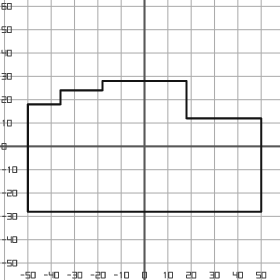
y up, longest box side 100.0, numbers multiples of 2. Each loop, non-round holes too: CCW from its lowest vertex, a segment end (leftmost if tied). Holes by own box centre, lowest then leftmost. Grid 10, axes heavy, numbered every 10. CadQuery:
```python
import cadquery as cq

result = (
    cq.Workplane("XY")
    .moveTo(-50.0, -28.0)
    .lineTo(50.0, -28.0)
    .lineTo(50.0, 12.0)
    .lineTo(18.0, 12.0)
    .lineTo(18.0, 28.0)
    .lineTo(-18.0, 28.0)
    .lineTo(-18.0, 24.0)
    .lineTo(-36.0, 24.0)
    .lineTo(-36.0, 18.0)
    .lineTo(-50.0, 18.0)
    .close()
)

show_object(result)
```